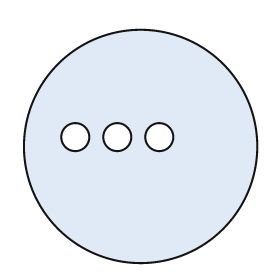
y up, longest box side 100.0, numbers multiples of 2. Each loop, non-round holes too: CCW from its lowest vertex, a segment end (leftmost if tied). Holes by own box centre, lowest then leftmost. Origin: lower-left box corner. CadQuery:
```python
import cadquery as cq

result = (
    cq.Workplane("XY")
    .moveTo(50.0, 50.0)
    .circle(50.0)
    .moveTo(22.0, 54.0)
    .circle(6.0)
    .moveTo(40.0, 54.0)
    .circle(6.0)
    .moveTo(58.0, 54.0)
    .circle(6.0)
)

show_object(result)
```